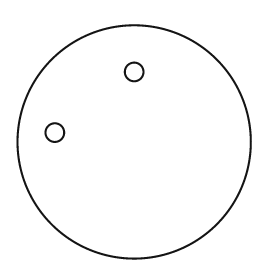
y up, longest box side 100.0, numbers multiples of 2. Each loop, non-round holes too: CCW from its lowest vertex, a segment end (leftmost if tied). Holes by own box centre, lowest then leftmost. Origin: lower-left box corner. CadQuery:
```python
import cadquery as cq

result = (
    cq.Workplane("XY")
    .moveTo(50.0, 50.0)
    .circle(50.0)
    .moveTo(16.0, 54.0)
    .circle(4.0)
    .moveTo(50.0, 80.0)
    .circle(4.0)
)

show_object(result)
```